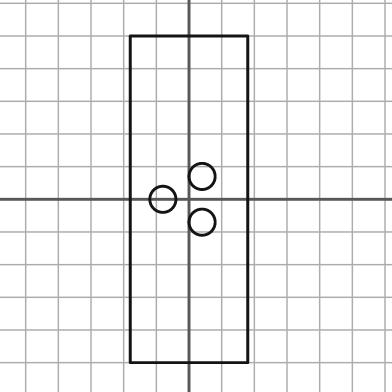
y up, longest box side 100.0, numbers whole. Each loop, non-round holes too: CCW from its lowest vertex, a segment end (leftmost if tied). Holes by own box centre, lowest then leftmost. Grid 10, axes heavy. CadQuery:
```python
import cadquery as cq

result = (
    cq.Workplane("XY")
    .moveTo(-18.0, -50.0)
    .lineTo(18.0, -50.0)
    .lineTo(18.0, 50.0)
    .lineTo(-18.0, 50.0)
    .close()
    .moveTo(4.0, -7.0)
    .circle(4.0)
    .moveTo(-8.0, 0.0)
    .circle(4.0)
    .moveTo(4.0, 7.0)
    .circle(4.0)
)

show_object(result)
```